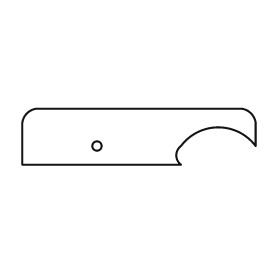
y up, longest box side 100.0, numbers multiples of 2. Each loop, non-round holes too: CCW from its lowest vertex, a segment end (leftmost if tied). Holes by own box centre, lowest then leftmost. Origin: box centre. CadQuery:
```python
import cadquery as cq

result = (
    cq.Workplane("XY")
    .moveTo(-50.0, -12.0)
    .lineTo(18.0, -12.0)
    .threePointArc((16.0, -8.0), (18.0, -4.0))
    .threePointArc((34.0, 4.0), (50.0, -4.0))
    .lineTo(50.0, 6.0)
    .threePointArc((48.0, 10.0), (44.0, 12.0))
    .lineTo(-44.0, 12.0)
    .threePointArc((-48.0, 10.0), (-50.0, 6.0))
    .close()
    .moveTo(-18.0, -4.0)
    .circle(2.0)
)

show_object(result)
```